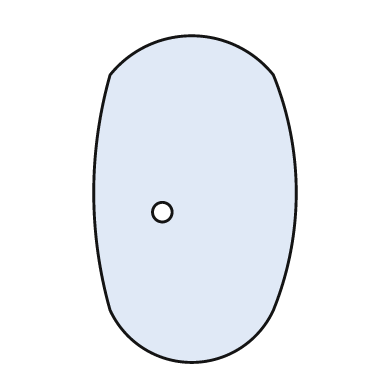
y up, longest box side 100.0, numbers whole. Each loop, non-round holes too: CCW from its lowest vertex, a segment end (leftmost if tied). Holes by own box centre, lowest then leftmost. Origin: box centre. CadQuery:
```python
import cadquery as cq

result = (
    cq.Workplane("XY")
    .moveTo(-26.0, -34.0)
    .threePointArc((-1.0, -50.0), (24.0, -34.0))
    .threePointArc((31.0, 2.0), (24.0, 38.0))
    .threePointArc((-1.0, 50.0), (-26.0, 38.0))
    .threePointArc((-31.0, 2.0), (-26.0, -34.0))
    .close()
    .moveTo(-10.0, -4.0)
    .circle(3.0)
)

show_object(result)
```